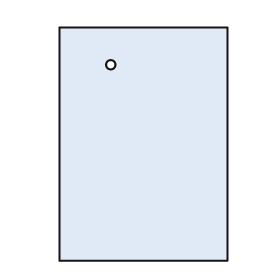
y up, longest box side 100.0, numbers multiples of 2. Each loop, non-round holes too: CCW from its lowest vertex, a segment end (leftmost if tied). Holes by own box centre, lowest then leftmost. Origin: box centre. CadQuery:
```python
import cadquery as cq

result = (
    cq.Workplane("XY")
    .moveTo(-36.0, -50.0)
    .lineTo(36.0, -50.0)
    .lineTo(36.0, 50.0)
    .lineTo(-36.0, 50.0)
    .close()
    .moveTo(-14.0, 34.0)
    .circle(2.0)
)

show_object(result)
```